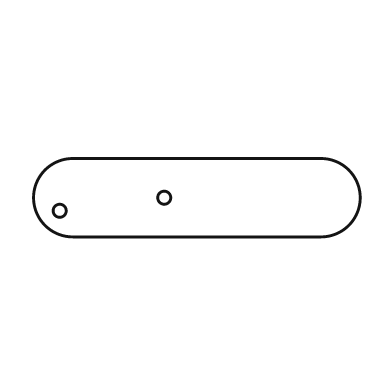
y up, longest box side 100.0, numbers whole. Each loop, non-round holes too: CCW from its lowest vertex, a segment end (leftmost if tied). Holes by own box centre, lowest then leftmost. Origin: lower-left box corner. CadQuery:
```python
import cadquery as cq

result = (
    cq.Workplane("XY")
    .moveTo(12.0, 0.0)
    .lineTo(88.0, 0.0)
    .threePointArc((100.0, 12.0), (88.0, 24.0))
    .lineTo(12.0, 24.0)
    .threePointArc((0.0, 12.0), (12.0, 0.0))
    .close()
    .moveTo(8.0, 8.0)
    .circle(2.0)
    .moveTo(40.0, 12.0)
    .circle(2.0)
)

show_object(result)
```